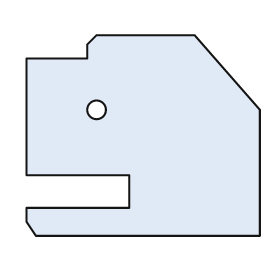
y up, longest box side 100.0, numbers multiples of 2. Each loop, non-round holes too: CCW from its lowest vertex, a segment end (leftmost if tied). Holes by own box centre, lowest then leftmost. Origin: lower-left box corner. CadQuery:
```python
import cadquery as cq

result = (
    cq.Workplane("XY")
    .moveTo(4.0, 0.0)
    .lineTo(100.0, 0.0)
    .lineTo(100.0, 54.0)
    .lineTo(72.0, 86.0)
    .lineTo(30.0, 86.0)
    .lineTo(26.0, 82.0)
    .lineTo(26.0, 76.0)
    .lineTo(0.0, 76.0)
    .lineTo(0.0, 26.0)
    .lineTo(44.0, 26.0)
    .lineTo(44.0, 12.0)
    .lineTo(0.0, 12.0)
    .lineTo(0.0, 6.0)
    .close()
    .moveTo(30.0, 54.0)
    .circle(4.0)
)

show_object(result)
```